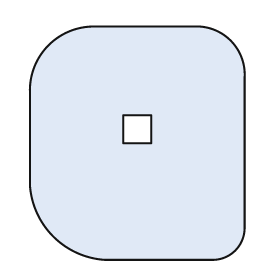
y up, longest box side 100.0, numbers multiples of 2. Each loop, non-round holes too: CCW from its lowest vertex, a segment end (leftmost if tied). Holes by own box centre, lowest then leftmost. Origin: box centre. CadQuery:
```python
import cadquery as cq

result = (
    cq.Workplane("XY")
    .moveTo(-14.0, -50.0)
    .lineTo(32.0, -50.0)
    .threePointArc((42.0, -46.0), (46.0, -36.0))
    .lineTo(46.0, 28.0)
    .threePointArc((40.0, 44.0), (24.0, 50.0))
    .lineTo(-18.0, 50.0)
    .threePointArc((-38.0, 42.0), (-46.0, 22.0))
    .lineTo(-46.0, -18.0)
    .threePointArc((-36.0, -40.0), (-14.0, -50.0))
    .close()
    .moveTo(-6.0, 0.0)
    .lineTo(6.0, 0.0)
    .lineTo(6.0, 12.0)
    .lineTo(-6.0, 12.0)
    .close()
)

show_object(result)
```